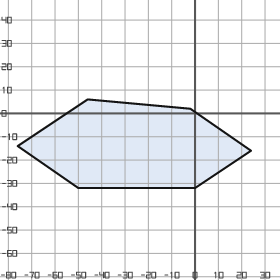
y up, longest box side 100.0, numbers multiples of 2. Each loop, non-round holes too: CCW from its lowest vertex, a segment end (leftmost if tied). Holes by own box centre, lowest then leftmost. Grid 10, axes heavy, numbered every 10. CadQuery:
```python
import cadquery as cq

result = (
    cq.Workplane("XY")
    .moveTo(-50.0, -32.0)
    .lineTo(0.0, -32.0)
    .lineTo(24.0, -16.0)
    .lineTo(-2.0, 2.0)
    .lineTo(-46.0, 6.0)
    .lineTo(-76.0, -14.0)
    .close()
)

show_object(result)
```